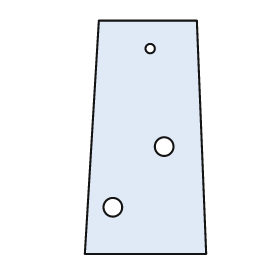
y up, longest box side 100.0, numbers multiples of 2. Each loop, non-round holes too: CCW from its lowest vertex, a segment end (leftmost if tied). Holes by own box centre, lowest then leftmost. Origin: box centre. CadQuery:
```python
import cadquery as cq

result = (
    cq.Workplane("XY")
    .moveTo(-26.0, -50.0)
    .lineTo(26.0, -50.0)
    .lineTo(22.0, 50.0)
    .lineTo(-20.0, 50.0)
    .close()
    .moveTo(-14.0, -30.0)
    .circle(4.0)
    .moveTo(8.0, -4.0)
    .circle(4.0)
    .moveTo(2.0, 38.0)
    .circle(2.0)
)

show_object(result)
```